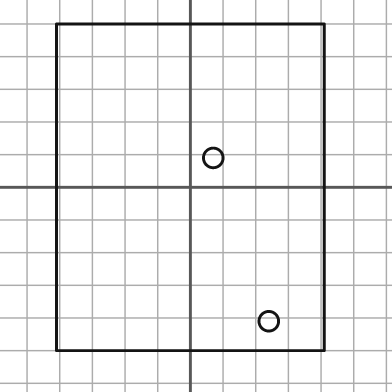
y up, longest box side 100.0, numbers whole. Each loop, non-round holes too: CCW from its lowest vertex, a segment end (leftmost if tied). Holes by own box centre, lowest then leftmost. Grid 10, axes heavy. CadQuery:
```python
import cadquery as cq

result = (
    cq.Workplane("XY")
    .moveTo(-41.0, -50.0)
    .lineTo(41.0, -50.0)
    .lineTo(41.0, 50.0)
    .lineTo(-41.0, 50.0)
    .close()
    .moveTo(24.0, -41.0)
    .circle(3.0)
    .moveTo(7.0, 9.0)
    .circle(3.0)
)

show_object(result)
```